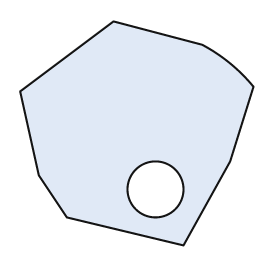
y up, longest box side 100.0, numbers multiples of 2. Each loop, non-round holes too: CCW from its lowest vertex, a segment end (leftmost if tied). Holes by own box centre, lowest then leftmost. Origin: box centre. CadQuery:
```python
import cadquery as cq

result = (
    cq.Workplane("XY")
    .moveTo(20.0, -48.0)
    .lineTo(40.0, -12.0)
    .lineTo(50.0, 20.0)
    .threePointArc((40.0, 30.0), (28.0, 38.0))
    .lineTo(-10.0, 48.0)
    .lineTo(-50.0, 18.0)
    .lineTo(-42.0, -18.0)
    .lineTo(-30.0, -36.0)
    .close()
    .moveTo(8.0, -24.0)
    .circle(12.0)
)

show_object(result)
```